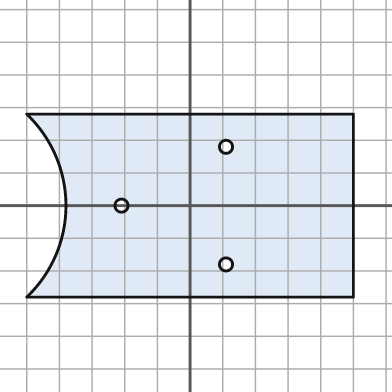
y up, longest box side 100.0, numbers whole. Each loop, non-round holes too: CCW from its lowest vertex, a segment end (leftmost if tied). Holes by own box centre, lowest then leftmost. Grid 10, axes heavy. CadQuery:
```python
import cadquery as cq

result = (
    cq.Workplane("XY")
    .moveTo(-50.0, -28.0)
    .lineTo(50.0, -28.0)
    .lineTo(50.0, 28.0)
    .lineTo(-50.0, 28.0)
    .threePointArc((-38.0, 0.0), (-50.0, -28.0))
    .close()
    .moveTo(11.0, -18.0)
    .circle(2.0)
    .moveTo(-21.0, 0.0)
    .circle(2.0)
    .moveTo(11.0, 18.0)
    .circle(2.0)
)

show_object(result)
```